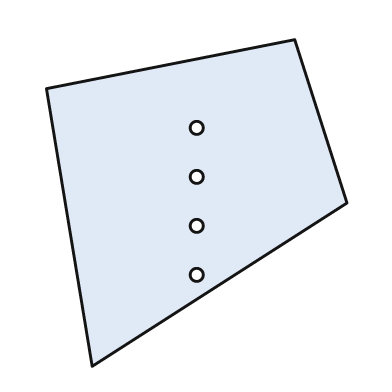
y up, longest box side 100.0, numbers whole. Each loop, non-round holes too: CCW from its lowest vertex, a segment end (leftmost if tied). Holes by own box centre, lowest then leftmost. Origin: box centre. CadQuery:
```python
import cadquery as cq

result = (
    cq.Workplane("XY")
    .moveTo(-32.0, -50.0)
    .lineTo(46.0, 0.0)
    .lineTo(30.0, 50.0)
    .lineTo(-46.0, 35.0)
    .close()
    .moveTo(0.0, -22.0)
    .circle(2.0)
    .moveTo(0.0, -7.0)
    .circle(2.0)
    .moveTo(0.0, 8.0)
    .circle(2.0)
    .moveTo(0.0, 23.0)
    .circle(2.0)
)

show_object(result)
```